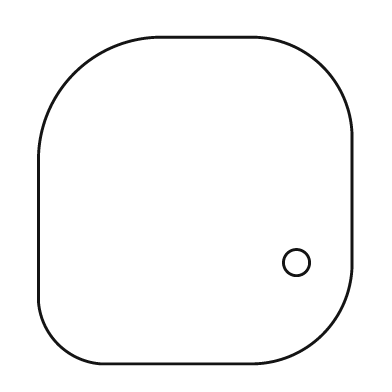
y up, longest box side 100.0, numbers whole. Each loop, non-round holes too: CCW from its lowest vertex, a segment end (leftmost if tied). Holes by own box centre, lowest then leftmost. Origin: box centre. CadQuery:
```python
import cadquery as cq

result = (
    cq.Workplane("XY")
    .moveTo(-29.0, -50.0)
    .lineTo(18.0, -50.0)
    .threePointArc((39.0, -41.0), (48.0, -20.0))
    .lineTo(48.0, 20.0)
    .threePointArc((39.0, 41.0), (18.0, 50.0))
    .lineTo(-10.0, 50.0)
    .threePointArc((-37.0, 39.0), (-48.0, 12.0))
    .lineTo(-48.0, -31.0)
    .threePointArc((-42.0, -44.0), (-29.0, -50.0))
    .close()
    .moveTo(31.0, -19.0)
    .circle(4.0)
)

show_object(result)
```